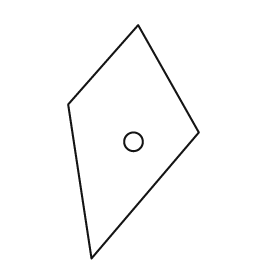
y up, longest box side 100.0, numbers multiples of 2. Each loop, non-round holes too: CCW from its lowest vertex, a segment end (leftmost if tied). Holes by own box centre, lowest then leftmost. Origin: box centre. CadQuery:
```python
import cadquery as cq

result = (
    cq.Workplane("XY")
    .moveTo(-18.0, -50.0)
    .lineTo(28.0, 4.0)
    .lineTo(2.0, 50.0)
    .lineTo(-28.0, 16.0)
    .close()
    .moveTo(0.0, 0.0)
    .circle(4.0)
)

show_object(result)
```